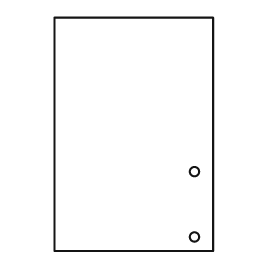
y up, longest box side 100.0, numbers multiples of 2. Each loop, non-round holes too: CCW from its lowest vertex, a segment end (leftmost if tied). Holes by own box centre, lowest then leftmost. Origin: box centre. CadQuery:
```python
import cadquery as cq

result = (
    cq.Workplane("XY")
    .moveTo(-34.0, -50.0)
    .lineTo(34.0, -50.0)
    .lineTo(34.0, 50.0)
    .lineTo(-34.0, 50.0)
    .close()
    .moveTo(26.0, -44.0)
    .circle(2.0)
    .moveTo(26.0, -16.0)
    .circle(2.0)
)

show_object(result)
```